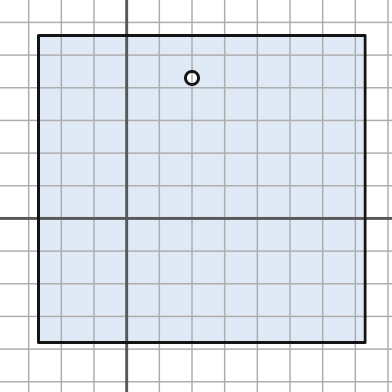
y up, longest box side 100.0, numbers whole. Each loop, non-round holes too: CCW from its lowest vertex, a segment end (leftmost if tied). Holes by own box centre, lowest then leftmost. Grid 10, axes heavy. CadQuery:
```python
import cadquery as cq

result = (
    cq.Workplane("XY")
    .moveTo(-27.0, -38.0)
    .lineTo(73.0, -38.0)
    .lineTo(73.0, 56.0)
    .lineTo(-27.0, 56.0)
    .close()
    .moveTo(20.0, 43.0)
    .circle(2.0)
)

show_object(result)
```